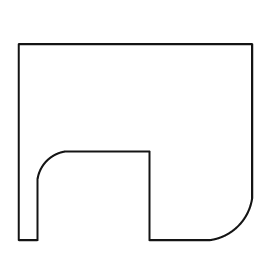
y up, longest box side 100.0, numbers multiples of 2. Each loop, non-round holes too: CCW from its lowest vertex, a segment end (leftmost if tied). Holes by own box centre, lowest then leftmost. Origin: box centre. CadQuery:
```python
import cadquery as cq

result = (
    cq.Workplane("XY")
    .moveTo(-50.0, -42.0)
    .lineTo(-42.0, -42.0)
    .lineTo(-42.0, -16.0)
    .threePointArc((-38.0, -8.0), (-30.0, -4.0))
    .lineTo(6.0, -4.0)
    .lineTo(6.0, -42.0)
    .lineTo(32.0, -42.0)
    .threePointArc((44.0, -36.0), (50.0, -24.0))
    .lineTo(50.0, 42.0)
    .lineTo(-50.0, 42.0)
    .close()
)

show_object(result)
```